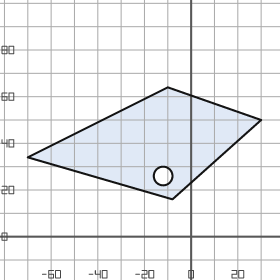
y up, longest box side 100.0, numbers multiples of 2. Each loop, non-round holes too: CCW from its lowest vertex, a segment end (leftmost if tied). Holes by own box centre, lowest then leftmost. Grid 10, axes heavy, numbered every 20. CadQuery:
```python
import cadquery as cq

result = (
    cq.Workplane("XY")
    .moveTo(-8.0, 16.0)
    .lineTo(30.0, 50.0)
    .lineTo(-10.0, 64.0)
    .lineTo(-70.0, 34.0)
    .close()
    .moveTo(-12.0, 26.0)
    .circle(4.0)
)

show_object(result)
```